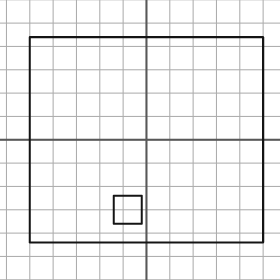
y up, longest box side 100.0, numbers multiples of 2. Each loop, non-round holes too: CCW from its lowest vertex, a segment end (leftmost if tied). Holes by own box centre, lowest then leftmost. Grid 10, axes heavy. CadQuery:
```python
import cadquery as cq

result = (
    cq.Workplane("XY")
    .moveTo(-50.0, -44.0)
    .lineTo(50.0, -44.0)
    .lineTo(50.0, 44.0)
    .lineTo(-50.0, 44.0)
    .close()
    .moveTo(-14.0, -36.0)
    .lineTo(-2.0, -36.0)
    .lineTo(-2.0, -24.0)
    .lineTo(-14.0, -24.0)
    .close()
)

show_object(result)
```